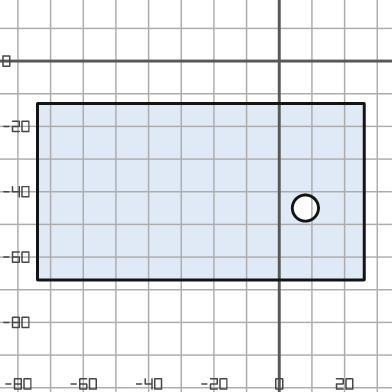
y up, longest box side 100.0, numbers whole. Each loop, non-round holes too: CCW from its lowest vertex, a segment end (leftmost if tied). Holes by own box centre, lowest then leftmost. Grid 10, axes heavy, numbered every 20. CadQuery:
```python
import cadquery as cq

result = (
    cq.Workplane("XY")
    .moveTo(-74.0, -67.0)
    .lineTo(26.0, -67.0)
    .lineTo(26.0, -13.0)
    .lineTo(-74.0, -13.0)
    .close()
    .moveTo(8.0, -45.0)
    .circle(4.0)
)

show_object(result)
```